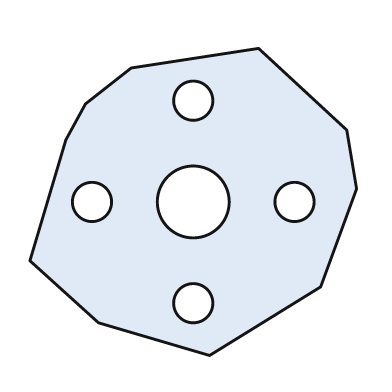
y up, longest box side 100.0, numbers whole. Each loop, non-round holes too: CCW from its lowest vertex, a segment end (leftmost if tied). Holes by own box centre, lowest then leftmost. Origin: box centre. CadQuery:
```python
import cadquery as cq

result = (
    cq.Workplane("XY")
    .moveTo(5.0, -47.0)
    .lineTo(39.0, -26.0)
    .lineTo(50.0, 4.0)
    .lineTo(47.0, 22.0)
    .lineTo(20.0, 47.0)
    .lineTo(-19.0, 41.0)
    .lineTo(-33.0, 30.0)
    .lineTo(-39.0, 19.0)
    .lineTo(-50.0, -18.0)
    .lineTo(-29.0, -37.0)
    .close()
    .moveTo(0.0, -31.0)
    .circle(6.0)
    .moveTo(-31.0, 0.0)
    .circle(6.0)
    .moveTo(0.0, 0.0)
    .circle(11.0)
    .moveTo(31.0, 0.0)
    .circle(6.0)
    .moveTo(0.0, 31.0)
    .circle(6.0)
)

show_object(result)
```